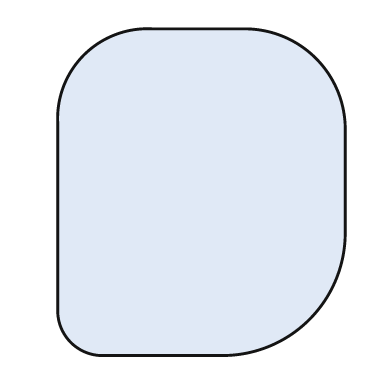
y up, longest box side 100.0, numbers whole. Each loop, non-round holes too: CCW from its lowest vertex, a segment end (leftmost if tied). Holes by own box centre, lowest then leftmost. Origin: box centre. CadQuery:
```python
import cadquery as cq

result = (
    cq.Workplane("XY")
    .moveTo(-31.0, -50.0)
    .lineTo(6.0, -50.0)
    .threePointArc((33.0, -39.0), (44.0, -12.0))
    .lineTo(44.0, 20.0)
    .threePointArc((35.0, 41.0), (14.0, 50.0))
    .lineTo(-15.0, 50.0)
    .threePointArc((-36.0, 42.0), (-44.0, 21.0))
    .lineTo(-44.0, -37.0)
    .threePointArc((-40.0, -46.0), (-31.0, -50.0))
    .close()
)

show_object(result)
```